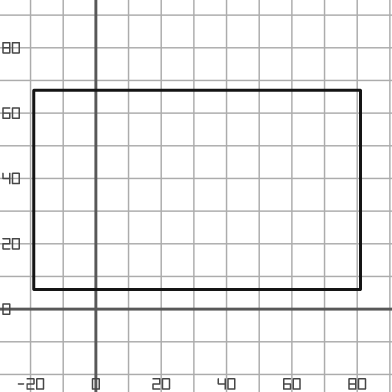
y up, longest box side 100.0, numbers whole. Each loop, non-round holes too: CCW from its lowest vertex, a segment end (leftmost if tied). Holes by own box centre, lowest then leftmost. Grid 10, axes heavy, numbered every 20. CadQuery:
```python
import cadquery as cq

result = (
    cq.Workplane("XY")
    .moveTo(-19.0, 6.0)
    .lineTo(81.0, 6.0)
    .lineTo(81.0, 67.0)
    .lineTo(-19.0, 67.0)
    .close()
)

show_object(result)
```